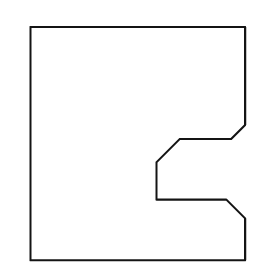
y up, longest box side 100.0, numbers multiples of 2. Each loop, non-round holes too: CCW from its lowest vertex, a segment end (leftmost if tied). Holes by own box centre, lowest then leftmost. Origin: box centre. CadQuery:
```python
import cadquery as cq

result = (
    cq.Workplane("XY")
    .moveTo(-46.0, -50.0)
    .lineTo(46.0, -50.0)
    .lineTo(46.0, -32.0)
    .lineTo(38.0, -24.0)
    .lineTo(8.0, -24.0)
    .lineTo(8.0, -8.0)
    .lineTo(18.0, 2.0)
    .lineTo(40.0, 2.0)
    .lineTo(46.0, 8.0)
    .lineTo(46.0, 50.0)
    .lineTo(-46.0, 50.0)
    .close()
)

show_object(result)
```